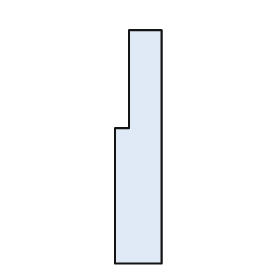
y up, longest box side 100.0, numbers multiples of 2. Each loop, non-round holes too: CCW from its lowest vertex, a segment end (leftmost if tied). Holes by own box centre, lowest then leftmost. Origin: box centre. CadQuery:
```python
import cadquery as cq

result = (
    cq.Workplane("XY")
    .moveTo(-10.0, -50.0)
    .lineTo(10.0, -50.0)
    .lineTo(10.0, 50.0)
    .lineTo(-4.0, 50.0)
    .lineTo(-4.0, 8.0)
    .lineTo(-10.0, 8.0)
    .close()
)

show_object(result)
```